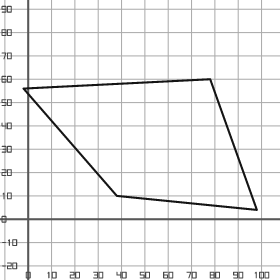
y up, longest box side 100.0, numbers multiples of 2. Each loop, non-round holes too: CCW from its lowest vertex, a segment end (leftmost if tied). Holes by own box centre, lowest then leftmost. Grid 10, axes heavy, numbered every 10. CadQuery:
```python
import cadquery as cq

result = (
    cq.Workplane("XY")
    .moveTo(98.0, 4.0)
    .lineTo(78.0, 60.0)
    .lineTo(-2.0, 56.0)
    .lineTo(38.0, 10.0)
    .close()
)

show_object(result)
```